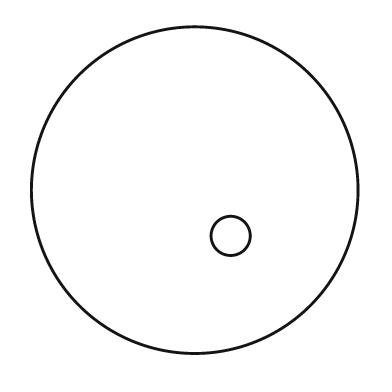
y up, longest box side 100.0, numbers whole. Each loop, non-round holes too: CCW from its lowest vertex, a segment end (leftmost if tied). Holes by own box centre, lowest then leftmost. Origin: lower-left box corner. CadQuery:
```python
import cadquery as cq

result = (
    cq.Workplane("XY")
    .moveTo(50.0, 50.0)
    .circle(50.0)
    .moveTo(61.0, 36.0)
    .circle(6.0)
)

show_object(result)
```